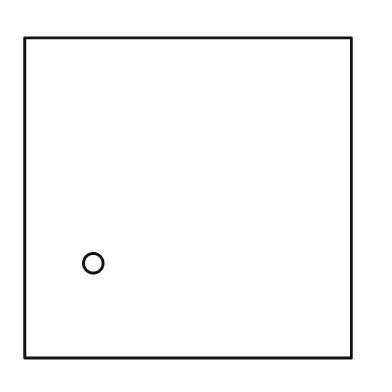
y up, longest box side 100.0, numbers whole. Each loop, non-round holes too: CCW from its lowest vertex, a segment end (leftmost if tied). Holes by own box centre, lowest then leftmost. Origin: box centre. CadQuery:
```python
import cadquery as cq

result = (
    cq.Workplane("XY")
    .moveTo(-50.0, -49.0)
    .lineTo(50.0, -49.0)
    .lineTo(50.0, 49.0)
    .lineTo(-50.0, 49.0)
    .close()
    .moveTo(-29.0, -20.0)
    .circle(3.0)
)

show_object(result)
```